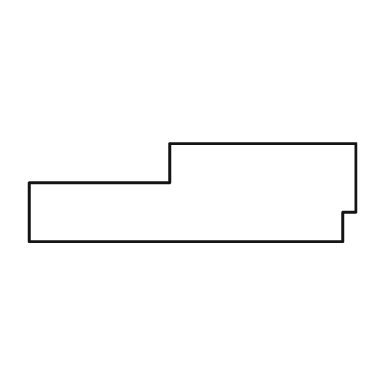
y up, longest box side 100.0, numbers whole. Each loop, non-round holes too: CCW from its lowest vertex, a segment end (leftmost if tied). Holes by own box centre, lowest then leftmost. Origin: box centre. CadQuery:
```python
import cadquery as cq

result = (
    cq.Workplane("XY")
    .moveTo(-50.0, -15.0)
    .lineTo(46.0, -15.0)
    .lineTo(46.0, -6.0)
    .lineTo(50.0, -6.0)
    .lineTo(50.0, 15.0)
    .lineTo(-7.0, 15.0)
    .lineTo(-7.0, 3.0)
    .lineTo(-50.0, 3.0)
    .close()
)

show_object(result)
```